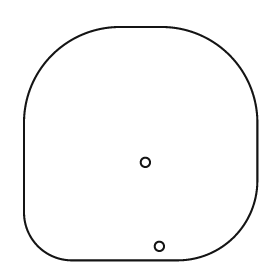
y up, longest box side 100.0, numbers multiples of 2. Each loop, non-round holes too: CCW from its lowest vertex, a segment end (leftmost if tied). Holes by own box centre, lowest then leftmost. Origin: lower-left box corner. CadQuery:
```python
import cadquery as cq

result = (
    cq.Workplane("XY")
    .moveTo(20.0, 0.0)
    .lineTo(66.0, 0.0)
    .threePointArc((90.0, 10.0), (100.0, 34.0))
    .lineTo(100.0, 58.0)
    .threePointArc((88.0, 88.0), (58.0, 100.0))
    .lineTo(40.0, 100.0)
    .threePointArc((12.0, 88.0), (0.0, 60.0))
    .lineTo(0.0, 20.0)
    .threePointArc((6.0, 6.0), (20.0, 0.0))
    .close()
    .moveTo(58.0, 6.0)
    .circle(2.0)
    .moveTo(52.0, 42.0)
    .circle(2.0)
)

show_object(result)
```